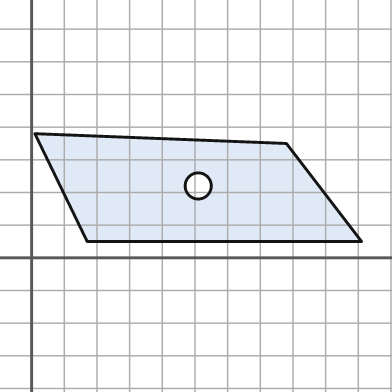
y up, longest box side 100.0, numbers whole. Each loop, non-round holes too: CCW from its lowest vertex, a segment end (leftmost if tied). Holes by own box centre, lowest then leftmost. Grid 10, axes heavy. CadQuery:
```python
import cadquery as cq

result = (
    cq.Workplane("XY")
    .moveTo(17.0, 5.0)
    .lineTo(101.0, 5.0)
    .lineTo(78.0, 35.0)
    .lineTo(1.0, 38.0)
    .close()
    .moveTo(51.0, 22.0)
    .circle(4.0)
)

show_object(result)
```